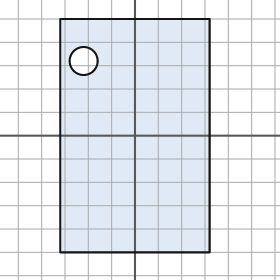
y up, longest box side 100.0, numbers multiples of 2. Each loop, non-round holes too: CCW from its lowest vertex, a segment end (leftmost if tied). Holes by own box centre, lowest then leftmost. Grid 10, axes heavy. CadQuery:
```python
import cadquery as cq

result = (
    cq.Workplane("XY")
    .moveTo(-32.0, -50.0)
    .lineTo(32.0, -50.0)
    .lineTo(32.0, 50.0)
    .lineTo(-32.0, 50.0)
    .close()
    .moveTo(-22.0, 32.0)
    .circle(6.0)
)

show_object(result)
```